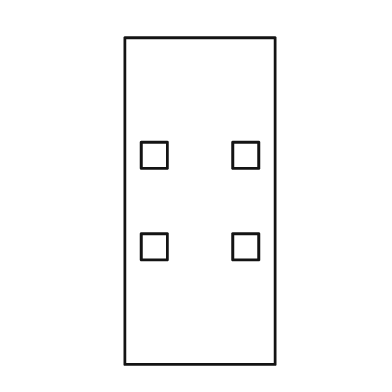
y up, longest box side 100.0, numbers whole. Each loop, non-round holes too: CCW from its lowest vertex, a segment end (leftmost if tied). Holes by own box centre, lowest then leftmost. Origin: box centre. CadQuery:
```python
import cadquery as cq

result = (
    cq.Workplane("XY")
    .moveTo(-23.0, -50.0)
    .lineTo(23.0, -50.0)
    .lineTo(23.0, 50.0)
    .lineTo(-23.0, 50.0)
    .close()
    .moveTo(-18.0, -18.0)
    .lineTo(-10.0, -18.0)
    .lineTo(-10.0, -10.0)
    .lineTo(-18.0, -10.0)
    .close()
    .moveTo(10.0, -18.0)
    .lineTo(18.0, -18.0)
    .lineTo(18.0, -10.0)
    .lineTo(10.0, -10.0)
    .close()
    .moveTo(-18.0, 10.0)
    .lineTo(-10.0, 10.0)
    .lineTo(-10.0, 18.0)
    .lineTo(-18.0, 18.0)
    .close()
    .moveTo(10.0, 10.0)
    .lineTo(18.0, 10.0)
    .lineTo(18.0, 18.0)
    .lineTo(10.0, 18.0)
    .close()
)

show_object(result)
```